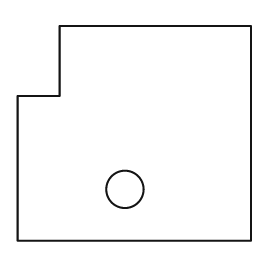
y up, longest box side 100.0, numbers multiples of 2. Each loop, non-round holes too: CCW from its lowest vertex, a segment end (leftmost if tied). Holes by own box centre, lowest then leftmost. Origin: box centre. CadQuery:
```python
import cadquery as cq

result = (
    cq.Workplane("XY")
    .moveTo(-50.0, -46.0)
    .lineTo(50.0, -46.0)
    .lineTo(50.0, 46.0)
    .lineTo(-32.0, 46.0)
    .lineTo(-32.0, 16.0)
    .lineTo(-50.0, 16.0)
    .close()
    .moveTo(-4.0, -24.0)
    .circle(8.0)
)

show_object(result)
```